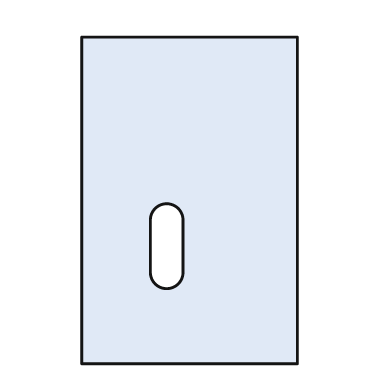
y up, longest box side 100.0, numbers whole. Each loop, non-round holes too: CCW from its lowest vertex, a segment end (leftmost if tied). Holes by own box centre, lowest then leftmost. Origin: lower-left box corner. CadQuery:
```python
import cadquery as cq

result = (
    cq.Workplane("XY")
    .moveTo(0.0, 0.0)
    .lineTo(66.0, 0.0)
    .lineTo(66.0, 100.0)
    .lineTo(0.0, 100.0)
    .close()
    .moveTo(21.0, 28.0)
    .threePointArc((26.0, 23.0), (31.0, 28.0))
    .lineTo(31.0, 44.0)
    .threePointArc((26.0, 49.0), (21.0, 44.0))
    .close()
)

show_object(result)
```